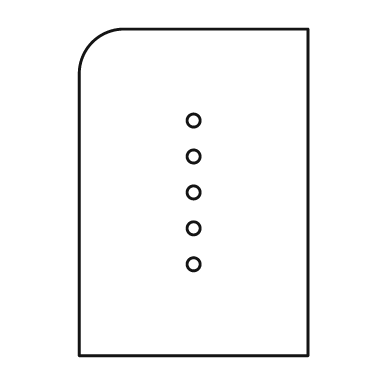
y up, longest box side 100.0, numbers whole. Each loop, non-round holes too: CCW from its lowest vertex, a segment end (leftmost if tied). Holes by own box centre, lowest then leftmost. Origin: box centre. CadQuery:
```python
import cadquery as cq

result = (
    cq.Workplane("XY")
    .moveTo(-35.0, -50.0)
    .lineTo(35.0, -50.0)
    .lineTo(35.0, 50.0)
    .lineTo(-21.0, 50.0)
    .threePointArc((-31.0, 46.0), (-35.0, 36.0))
    .close()
    .moveTo(0.0, -22.0)
    .circle(2.0)
    .moveTo(0.0, -11.0)
    .circle(2.0)
    .moveTo(0.0, 0.0)
    .circle(2.0)
    .moveTo(0.0, 11.0)
    .circle(2.0)
    .moveTo(0.0, 22.0)
    .circle(2.0)
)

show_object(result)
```